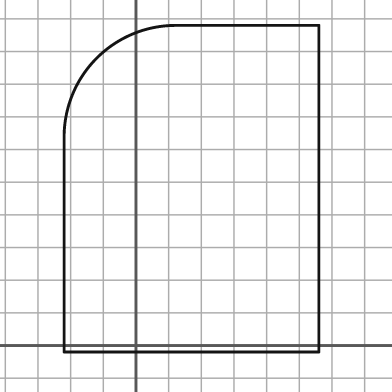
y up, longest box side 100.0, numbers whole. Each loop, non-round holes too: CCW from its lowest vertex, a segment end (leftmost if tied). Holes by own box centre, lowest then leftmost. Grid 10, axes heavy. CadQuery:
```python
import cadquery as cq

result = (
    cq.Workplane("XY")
    .moveTo(-22.0, -2.0)
    .lineTo(56.0, -2.0)
    .lineTo(56.0, 98.0)
    .lineTo(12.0, 98.0)
    .threePointArc((-12.0, 88.0), (-22.0, 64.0))
    .close()
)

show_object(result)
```